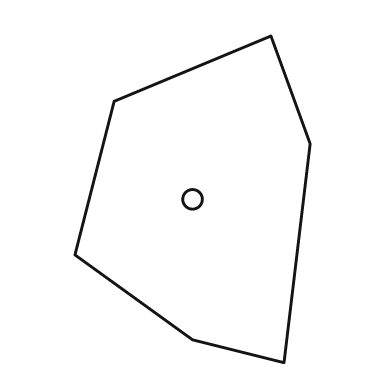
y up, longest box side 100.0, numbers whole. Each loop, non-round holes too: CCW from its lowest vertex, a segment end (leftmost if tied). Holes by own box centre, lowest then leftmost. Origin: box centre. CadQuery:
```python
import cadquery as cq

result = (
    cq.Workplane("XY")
    .moveTo(28.0, -50.0)
    .lineTo(36.0, 17.0)
    .lineTo(24.0, 50.0)
    .lineTo(-24.0, 30.0)
    .lineTo(-36.0, -17.0)
    .lineTo(0.0, -43.0)
    .close()
    .moveTo(0.0, 0.0)
    .circle(3.0)
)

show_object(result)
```